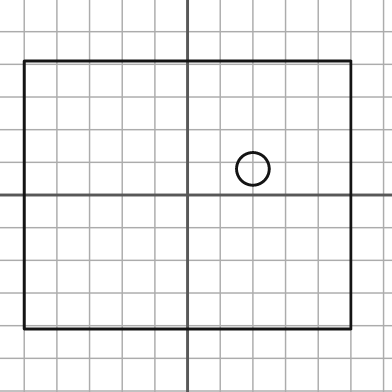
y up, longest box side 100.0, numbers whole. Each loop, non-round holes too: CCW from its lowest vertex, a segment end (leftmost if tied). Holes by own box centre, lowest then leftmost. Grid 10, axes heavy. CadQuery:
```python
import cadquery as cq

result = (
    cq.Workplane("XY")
    .moveTo(-50.0, -41.0)
    .lineTo(50.0, -41.0)
    .lineTo(50.0, 41.0)
    .lineTo(-50.0, 41.0)
    .close()
    .moveTo(20.0, 8.0)
    .circle(5.0)
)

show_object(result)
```